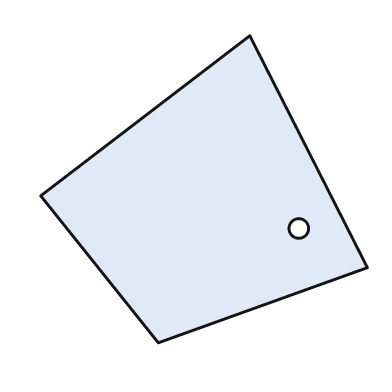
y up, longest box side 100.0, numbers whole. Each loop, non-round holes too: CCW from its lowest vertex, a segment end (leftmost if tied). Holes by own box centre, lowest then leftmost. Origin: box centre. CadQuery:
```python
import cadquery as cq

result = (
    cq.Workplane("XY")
    .moveTo(-14.0, -47.0)
    .lineTo(50.0, -24.0)
    .lineTo(14.0, 47.0)
    .lineTo(-50.0, -2.0)
    .close()
    .moveTo(29.0, -12.0)
    .circle(3.0)
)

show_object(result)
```